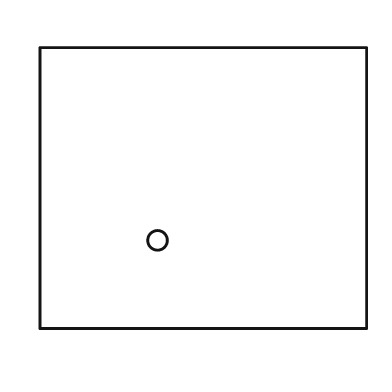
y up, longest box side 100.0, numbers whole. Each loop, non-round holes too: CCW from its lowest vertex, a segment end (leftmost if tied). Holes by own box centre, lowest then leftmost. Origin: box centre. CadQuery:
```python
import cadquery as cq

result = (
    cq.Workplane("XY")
    .moveTo(-50.0, -43.0)
    .lineTo(50.0, -43.0)
    .lineTo(50.0, 43.0)
    .lineTo(-50.0, 43.0)
    .close()
    .moveTo(-14.0, -16.0)
    .circle(3.0)
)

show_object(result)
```